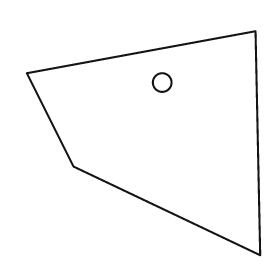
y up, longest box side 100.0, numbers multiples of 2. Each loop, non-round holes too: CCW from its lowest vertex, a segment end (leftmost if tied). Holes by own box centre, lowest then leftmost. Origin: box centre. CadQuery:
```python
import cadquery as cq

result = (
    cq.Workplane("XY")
    .moveTo(50.0, -48.0)
    .lineTo(48.0, 48.0)
    .lineTo(-50.0, 30.0)
    .lineTo(-30.0, -10.0)
    .close()
    .moveTo(8.0, 26.0)
    .circle(4.0)
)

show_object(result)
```